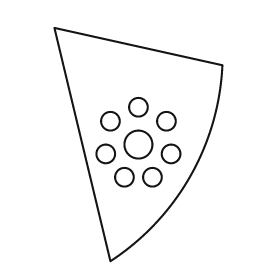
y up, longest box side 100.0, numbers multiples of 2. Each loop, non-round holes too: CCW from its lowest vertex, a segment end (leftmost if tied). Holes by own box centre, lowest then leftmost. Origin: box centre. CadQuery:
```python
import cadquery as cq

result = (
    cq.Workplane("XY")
    .moveTo(-12.0, -50.0)
    .threePointArc((22.0, -14.0), (36.0, 34.0))
    .lineTo(-36.0, 50.0)
    .close()
    .moveTo(-6.0, -14.0)
    .circle(4.0)
    .moveTo(6.0, -14.0)
    .circle(4.0)
    .moveTo(-14.0, -4.0)
    .circle(4.0)
    .moveTo(14.0, -4.0)
    .circle(4.0)
    .moveTo(0.0, 0.0)
    .circle(6.0)
    .moveTo(-12.0, 10.0)
    .circle(4.0)
    .moveTo(12.0, 10.0)
    .circle(4.0)
    .moveTo(0.0, 16.0)
    .circle(4.0)
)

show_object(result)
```